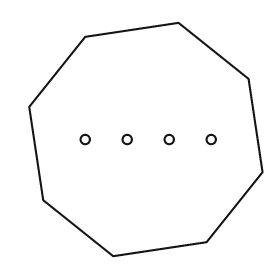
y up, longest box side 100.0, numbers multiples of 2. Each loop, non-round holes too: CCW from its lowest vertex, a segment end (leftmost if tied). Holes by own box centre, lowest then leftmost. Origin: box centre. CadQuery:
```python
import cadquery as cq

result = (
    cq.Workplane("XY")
    .moveTo(-14.0, -50.0)
    .lineTo(26.0, -44.0)
    .lineTo(50.0, -14.0)
    .lineTo(44.0, 26.0)
    .lineTo(14.0, 50.0)
    .lineTo(-26.0, 44.0)
    .lineTo(-50.0, 14.0)
    .lineTo(-44.0, -26.0)
    .close()
    .moveTo(-26.0, 0.0)
    .circle(2.0)
    .moveTo(-8.0, 0.0)
    .circle(2.0)
    .moveTo(10.0, 0.0)
    .circle(2.0)
    .moveTo(28.0, 0.0)
    .circle(2.0)
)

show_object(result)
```